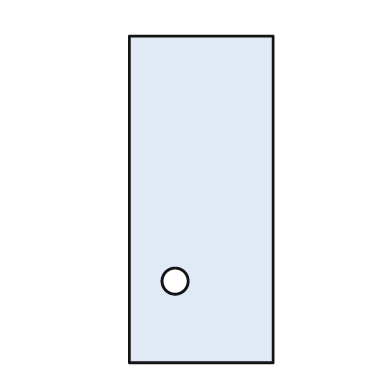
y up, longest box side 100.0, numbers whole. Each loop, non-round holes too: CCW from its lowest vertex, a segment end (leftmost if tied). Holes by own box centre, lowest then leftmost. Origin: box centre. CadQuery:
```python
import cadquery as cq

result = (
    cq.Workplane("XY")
    .moveTo(-22.0, -50.0)
    .lineTo(22.0, -50.0)
    .lineTo(22.0, 50.0)
    .lineTo(-22.0, 50.0)
    .close()
    .moveTo(-8.0, -25.0)
    .circle(4.0)
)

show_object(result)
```